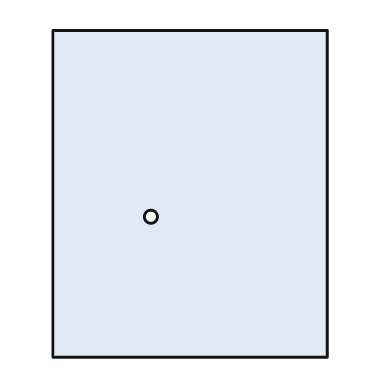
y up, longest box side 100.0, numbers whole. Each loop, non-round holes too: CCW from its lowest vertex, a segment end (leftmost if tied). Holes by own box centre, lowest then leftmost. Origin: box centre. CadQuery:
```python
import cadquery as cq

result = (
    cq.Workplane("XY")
    .moveTo(-42.0, -50.0)
    .lineTo(42.0, -50.0)
    .lineTo(42.0, 50.0)
    .lineTo(-42.0, 50.0)
    .close()
    .moveTo(-12.0, -7.0)
    .circle(2.0)
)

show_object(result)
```